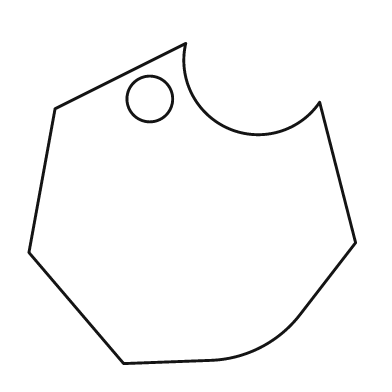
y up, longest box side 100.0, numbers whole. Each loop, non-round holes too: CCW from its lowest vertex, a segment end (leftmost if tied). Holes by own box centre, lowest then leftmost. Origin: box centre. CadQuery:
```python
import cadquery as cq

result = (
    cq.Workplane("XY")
    .moveTo(-21.0, -49.0)
    .lineTo(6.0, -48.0)
    .threePointArc((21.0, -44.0), (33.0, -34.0))
    .lineTo(50.0, -12.0)
    .lineTo(39.0, 31.0)
    .threePointArc((11.0, 23.0), (-2.0, 49.0))
    .lineTo(-42.0, 29.0)
    .lineTo(-50.0, -15.0)
    .close()
    .moveTo(-13.0, 32.0)
    .circle(7.0)
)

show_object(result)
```